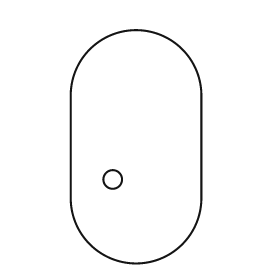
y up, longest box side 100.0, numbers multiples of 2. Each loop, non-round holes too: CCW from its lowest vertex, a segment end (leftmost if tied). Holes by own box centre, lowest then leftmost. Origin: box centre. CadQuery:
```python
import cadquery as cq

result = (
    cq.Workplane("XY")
    .moveTo(-28.0, -22.0)
    .threePointArc((0.0, -50.0), (28.0, -22.0))
    .lineTo(28.0, 22.0)
    .threePointArc((0.0, 50.0), (-28.0, 22.0))
    .close()
    .moveTo(-10.0, -14.0)
    .circle(4.0)
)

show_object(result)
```